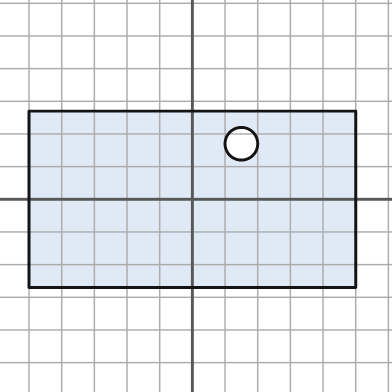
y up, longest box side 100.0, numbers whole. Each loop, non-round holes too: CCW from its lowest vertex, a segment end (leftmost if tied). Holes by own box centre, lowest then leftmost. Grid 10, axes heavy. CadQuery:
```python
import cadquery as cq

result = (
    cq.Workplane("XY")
    .moveTo(-50.0, -27.0)
    .lineTo(50.0, -27.0)
    .lineTo(50.0, 27.0)
    .lineTo(-50.0, 27.0)
    .close()
    .moveTo(15.0, 17.0)
    .circle(5.0)
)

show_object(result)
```